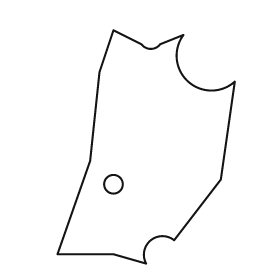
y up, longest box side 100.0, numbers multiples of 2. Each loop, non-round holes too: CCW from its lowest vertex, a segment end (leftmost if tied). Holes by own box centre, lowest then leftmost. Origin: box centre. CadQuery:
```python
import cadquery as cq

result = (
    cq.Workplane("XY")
    .moveTo(0.0, -50.0)
    .threePointArc((2.0, -40.0), (12.0, -40.0))
    .lineTo(32.0, -14.0)
    .lineTo(38.0, 28.0)
    .threePointArc((18.0, 28.0), (16.0, 48.0))
    .lineTo(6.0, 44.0)
    .threePointArc((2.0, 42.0), (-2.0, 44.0))
    .lineTo(-14.0, 50.0)
    .lineTo(-20.0, 32.0)
    .lineTo(-24.0, -6.0)
    .lineTo(-38.0, -46.0)
    .lineTo(-14.0, -46.0)
    .close()
    .moveTo(-14.0, -16.0)
    .circle(4.0)
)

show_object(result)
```